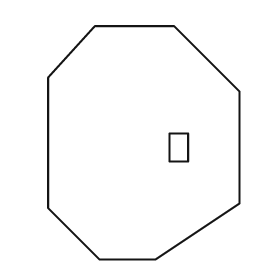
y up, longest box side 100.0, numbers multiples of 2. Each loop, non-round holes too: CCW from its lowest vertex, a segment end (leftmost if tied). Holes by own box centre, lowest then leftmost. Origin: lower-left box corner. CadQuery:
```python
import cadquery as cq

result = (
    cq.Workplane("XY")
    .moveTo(22.0, 0.0)
    .lineTo(46.0, 0.0)
    .lineTo(82.0, 24.0)
    .lineTo(82.0, 72.0)
    .lineTo(54.0, 100.0)
    .lineTo(20.0, 100.0)
    .lineTo(0.0, 78.0)
    .lineTo(0.0, 22.0)
    .close()
    .moveTo(52.0, 42.0)
    .lineTo(60.0, 42.0)
    .lineTo(60.0, 54.0)
    .lineTo(52.0, 54.0)
    .close()
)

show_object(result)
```